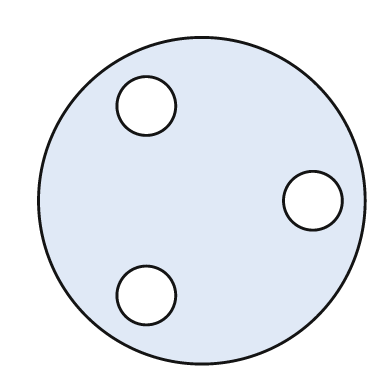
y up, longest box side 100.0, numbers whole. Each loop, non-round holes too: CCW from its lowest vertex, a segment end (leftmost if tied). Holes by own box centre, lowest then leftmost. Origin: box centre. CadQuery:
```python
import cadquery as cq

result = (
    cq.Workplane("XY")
    .moveTo(0.0, 0.0)
    .circle(50.0)
    .moveTo(-17.0, -29.0)
    .circle(9.0)
    .moveTo(34.0, 0.0)
    .circle(9.0)
    .moveTo(-17.0, 29.0)
    .circle(9.0)
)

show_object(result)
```